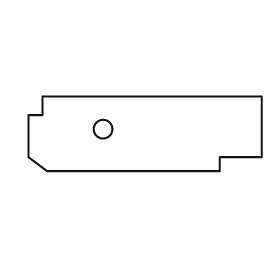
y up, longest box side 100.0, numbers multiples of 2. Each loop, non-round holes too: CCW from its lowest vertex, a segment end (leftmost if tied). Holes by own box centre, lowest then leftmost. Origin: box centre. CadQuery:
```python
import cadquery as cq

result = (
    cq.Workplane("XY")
    .moveTo(-42.0, -16.0)
    .lineTo(32.0, -16.0)
    .lineTo(32.0, -10.0)
    .lineTo(50.0, -10.0)
    .lineTo(50.0, 16.0)
    .lineTo(-44.0, 16.0)
    .lineTo(-44.0, 8.0)
    .lineTo(-50.0, 8.0)
    .lineTo(-50.0, -10.0)
    .close()
    .moveTo(-18.0, 2.0)
    .circle(4.0)
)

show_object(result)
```